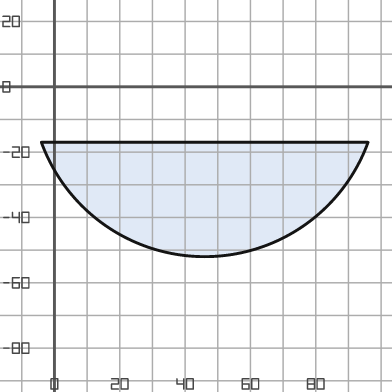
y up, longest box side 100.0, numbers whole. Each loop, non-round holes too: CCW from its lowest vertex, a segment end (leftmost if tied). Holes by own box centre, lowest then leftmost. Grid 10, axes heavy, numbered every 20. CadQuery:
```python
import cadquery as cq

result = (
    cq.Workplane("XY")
    .moveTo(-4.0, -17.0)
    .threePointArc((46.0, -52.0), (96.0, -17.0))
    .close()
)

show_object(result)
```